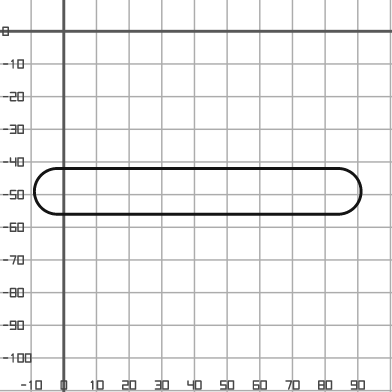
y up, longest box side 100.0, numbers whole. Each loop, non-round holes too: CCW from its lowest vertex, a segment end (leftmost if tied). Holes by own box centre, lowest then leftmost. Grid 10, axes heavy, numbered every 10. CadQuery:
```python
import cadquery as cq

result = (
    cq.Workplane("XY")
    .moveTo(-2.0, -56.0)
    .lineTo(84.0, -56.0)
    .threePointArc((91.0, -49.0), (84.0, -42.0))
    .lineTo(-2.0, -42.0)
    .threePointArc((-9.0, -49.0), (-2.0, -56.0))
    .close()
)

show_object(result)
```